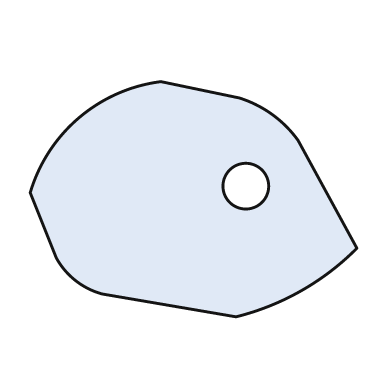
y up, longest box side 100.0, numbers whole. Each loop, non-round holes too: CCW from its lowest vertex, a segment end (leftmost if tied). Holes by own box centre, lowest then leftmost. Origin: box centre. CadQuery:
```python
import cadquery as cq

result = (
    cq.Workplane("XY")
    .moveTo(13.0, -36.0)
    .threePointArc((33.0, -28.0), (50.0, -15.0))
    .lineTo(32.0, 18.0)
    .threePointArc((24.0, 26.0), (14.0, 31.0))
    .lineTo(-10.0, 36.0)
    .threePointArc((-35.0, 25.0), (-50.0, 2.0))
    .lineTo(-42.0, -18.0)
    .threePointArc((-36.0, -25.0), (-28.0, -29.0))
    .close()
    .moveTo(16.0, 4.0)
    .circle(7.0)
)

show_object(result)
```